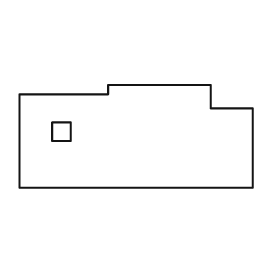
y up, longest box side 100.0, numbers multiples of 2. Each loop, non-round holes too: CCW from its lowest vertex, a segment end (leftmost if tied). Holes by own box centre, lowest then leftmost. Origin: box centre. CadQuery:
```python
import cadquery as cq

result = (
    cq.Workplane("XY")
    .moveTo(-50.0, -22.0)
    .lineTo(50.0, -22.0)
    .lineTo(50.0, 12.0)
    .lineTo(32.0, 12.0)
    .lineTo(32.0, 22.0)
    .lineTo(-12.0, 22.0)
    .lineTo(-12.0, 18.0)
    .lineTo(-50.0, 18.0)
    .close()
    .moveTo(-36.0, -2.0)
    .lineTo(-28.0, -2.0)
    .lineTo(-28.0, 6.0)
    .lineTo(-36.0, 6.0)
    .close()
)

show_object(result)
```